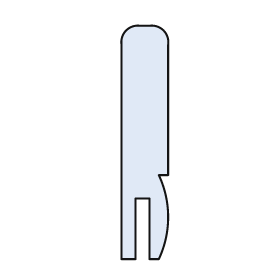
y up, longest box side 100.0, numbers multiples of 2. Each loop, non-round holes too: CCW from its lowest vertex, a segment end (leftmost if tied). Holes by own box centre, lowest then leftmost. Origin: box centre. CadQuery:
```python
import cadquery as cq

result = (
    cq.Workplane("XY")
    .moveTo(-10.0, -50.0)
    .lineTo(-4.0, -50.0)
    .lineTo(-4.0, -24.0)
    .lineTo(2.0, -24.0)
    .lineTo(2.0, -50.0)
    .lineTo(6.0, -50.0)
    .threePointArc((10.0, -32.0), (6.0, -14.0))
    .lineTo(10.0, -14.0)
    .lineTo(10.0, 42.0)
    .threePointArc((8.0, 48.0), (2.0, 50.0))
    .lineTo(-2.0, 50.0)
    .threePointArc((-8.0, 48.0), (-10.0, 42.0))
    .close()
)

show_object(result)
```